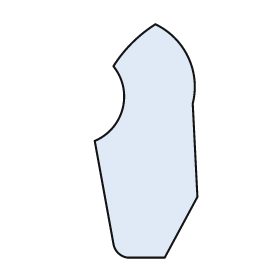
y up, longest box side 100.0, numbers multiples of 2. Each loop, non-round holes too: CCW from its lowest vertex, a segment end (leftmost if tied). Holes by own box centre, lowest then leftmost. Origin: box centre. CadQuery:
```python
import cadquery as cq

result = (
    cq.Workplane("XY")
    .moveTo(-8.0, -50.0)
    .lineTo(8.0, -50.0)
    .lineTo(22.0, -24.0)
    .lineTo(20.0, 16.0)
    .threePointArc((18.0, 36.0), (4.0, 50.0))
    .threePointArc((-6.0, 42.0), (-14.0, 32.0))
    .threePointArc((-10.0, 14.0), (-22.0, 0.0))
    .lineTo(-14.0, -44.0)
    .threePointArc((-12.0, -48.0), (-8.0, -50.0))
    .close()
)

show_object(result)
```